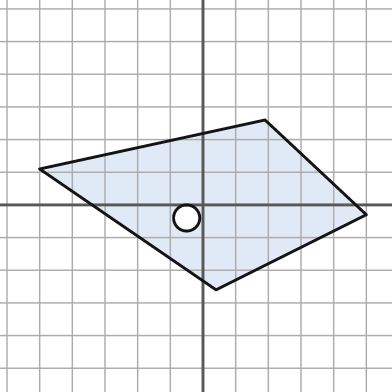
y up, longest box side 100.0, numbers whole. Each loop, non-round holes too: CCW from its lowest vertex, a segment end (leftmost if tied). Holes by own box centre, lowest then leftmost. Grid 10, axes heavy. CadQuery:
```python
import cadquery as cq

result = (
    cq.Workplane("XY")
    .moveTo(4.0, -26.0)
    .lineTo(50.0, -3.0)
    .lineTo(19.0, 26.0)
    .lineTo(-50.0, 11.0)
    .close()
    .moveTo(-5.0, -4.0)
    .circle(4.0)
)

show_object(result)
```